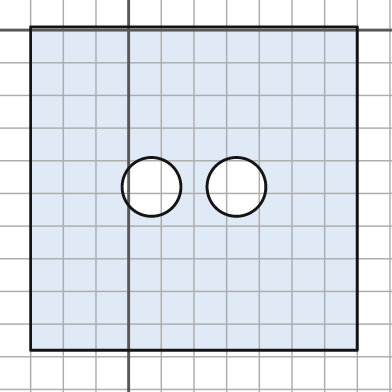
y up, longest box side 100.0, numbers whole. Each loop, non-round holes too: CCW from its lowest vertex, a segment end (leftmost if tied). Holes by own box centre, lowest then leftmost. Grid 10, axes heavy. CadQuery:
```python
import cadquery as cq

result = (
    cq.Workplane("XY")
    .moveTo(-30.0, -98.0)
    .lineTo(70.0, -98.0)
    .lineTo(70.0, 1.0)
    .lineTo(-30.0, 1.0)
    .close()
    .moveTo(7.0, -48.0)
    .circle(9.0)
    .moveTo(33.0, -48.0)
    .circle(9.0)
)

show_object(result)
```